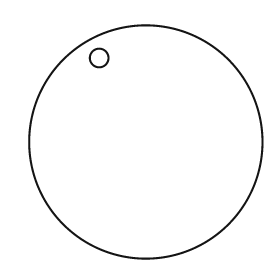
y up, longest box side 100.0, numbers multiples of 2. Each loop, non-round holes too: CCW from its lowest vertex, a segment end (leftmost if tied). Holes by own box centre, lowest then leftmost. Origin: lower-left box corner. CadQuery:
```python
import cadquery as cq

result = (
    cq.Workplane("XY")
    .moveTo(50.0, 50.0)
    .circle(50.0)
    .moveTo(30.0, 86.0)
    .circle(4.0)
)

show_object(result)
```